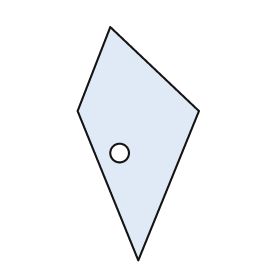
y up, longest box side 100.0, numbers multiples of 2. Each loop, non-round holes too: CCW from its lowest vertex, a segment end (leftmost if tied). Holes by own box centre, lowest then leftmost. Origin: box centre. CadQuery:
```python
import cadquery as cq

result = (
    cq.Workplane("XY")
    .moveTo(0.0, -50.0)
    .lineTo(26.0, 14.0)
    .lineTo(-12.0, 50.0)
    .lineTo(-26.0, 14.0)
    .close()
    .moveTo(-8.0, -4.0)
    .circle(4.0)
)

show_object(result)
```